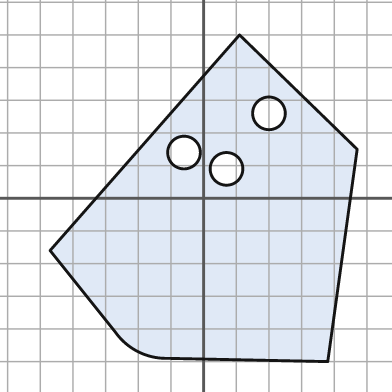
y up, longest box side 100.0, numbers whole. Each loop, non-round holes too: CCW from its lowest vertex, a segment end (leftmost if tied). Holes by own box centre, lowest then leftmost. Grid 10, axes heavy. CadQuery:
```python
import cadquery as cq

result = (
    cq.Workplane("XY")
    .moveTo(38.0, -50.0)
    .lineTo(47.0, 15.0)
    .lineTo(11.0, 50.0)
    .lineTo(-47.0, -16.0)
    .lineTo(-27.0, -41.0)
    .threePointArc((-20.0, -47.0), (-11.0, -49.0))
    .close()
    .moveTo(7.0, 9.0)
    .circle(5.0)
    .moveTo(-6.0, 14.0)
    .circle(5.0)
    .moveTo(20.0, 26.0)
    .circle(5.0)
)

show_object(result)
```